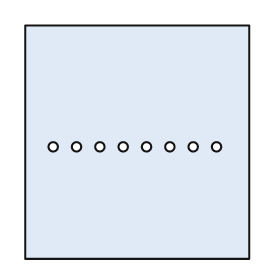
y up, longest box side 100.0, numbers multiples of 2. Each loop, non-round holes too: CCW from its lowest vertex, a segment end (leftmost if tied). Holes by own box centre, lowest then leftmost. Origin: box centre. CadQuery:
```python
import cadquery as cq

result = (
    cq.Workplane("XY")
    .moveTo(-48.0, -50.0)
    .lineTo(48.0, -50.0)
    .lineTo(48.0, 50.0)
    .lineTo(-48.0, 50.0)
    .close()
    .moveTo(-36.0, -2.0)
    .circle(2.0)
    .moveTo(-26.0, -2.0)
    .circle(2.0)
    .moveTo(-16.0, -2.0)
    .circle(2.0)
    .moveTo(-6.0, -2.0)
    .circle(2.0)
    .moveTo(4.0, -2.0)
    .circle(2.0)
    .moveTo(14.0, -2.0)
    .circle(2.0)
    .moveTo(24.0, -2.0)
    .circle(2.0)
    .moveTo(34.0, -2.0)
    .circle(2.0)
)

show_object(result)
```